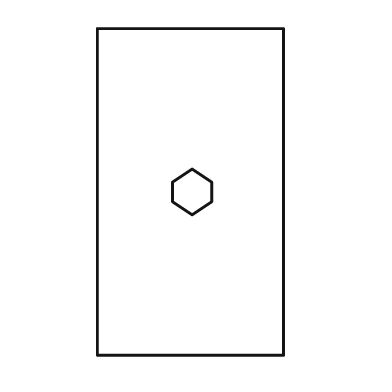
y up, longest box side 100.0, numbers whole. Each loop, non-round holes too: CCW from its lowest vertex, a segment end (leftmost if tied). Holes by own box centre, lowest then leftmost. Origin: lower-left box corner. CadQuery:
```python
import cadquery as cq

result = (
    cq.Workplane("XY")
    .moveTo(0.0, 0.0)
    .lineTo(57.0, 0.0)
    .lineTo(57.0, 100.0)
    .lineTo(0.0, 100.0)
    .close()
    .moveTo(29.0, 43.0)
    .lineTo(35.0, 47.0)
    .lineTo(35.0, 53.0)
    .lineTo(29.0, 57.0)
    .lineTo(23.0, 53.0)
    .lineTo(23.0, 47.0)
    .close()
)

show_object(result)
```